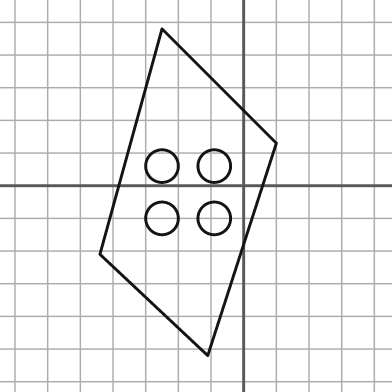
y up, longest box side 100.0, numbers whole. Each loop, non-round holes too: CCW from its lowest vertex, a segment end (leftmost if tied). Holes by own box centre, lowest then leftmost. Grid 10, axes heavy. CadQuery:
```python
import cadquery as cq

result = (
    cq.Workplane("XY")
    .moveTo(-11.0, -52.0)
    .lineTo(10.0, 13.0)
    .lineTo(-25.0, 48.0)
    .lineTo(-44.0, -21.0)
    .close()
    .moveTo(-25.0, -10.0)
    .circle(5.0)
    .moveTo(-9.0, -10.0)
    .circle(5.0)
    .moveTo(-25.0, 6.0)
    .circle(5.0)
    .moveTo(-9.0, 6.0)
    .circle(5.0)
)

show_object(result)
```